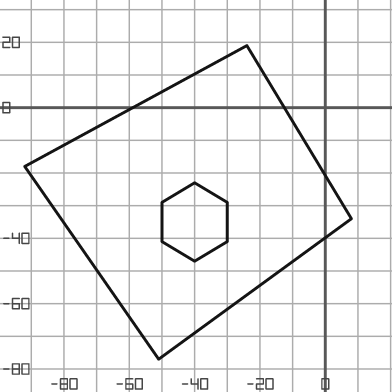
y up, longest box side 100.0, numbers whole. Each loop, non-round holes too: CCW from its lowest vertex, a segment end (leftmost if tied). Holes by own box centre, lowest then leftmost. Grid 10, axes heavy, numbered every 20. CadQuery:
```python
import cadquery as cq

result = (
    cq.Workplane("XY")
    .moveTo(-51.0, -77.0)
    .lineTo(8.0, -34.0)
    .lineTo(-24.0, 19.0)
    .lineTo(-92.0, -18.0)
    .close()
    .moveTo(-40.0, -47.0)
    .lineTo(-30.0, -41.0)
    .lineTo(-30.0, -29.0)
    .lineTo(-40.0, -23.0)
    .lineTo(-50.0, -29.0)
    .lineTo(-50.0, -41.0)
    .close()
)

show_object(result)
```